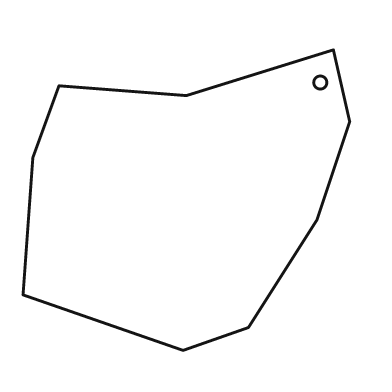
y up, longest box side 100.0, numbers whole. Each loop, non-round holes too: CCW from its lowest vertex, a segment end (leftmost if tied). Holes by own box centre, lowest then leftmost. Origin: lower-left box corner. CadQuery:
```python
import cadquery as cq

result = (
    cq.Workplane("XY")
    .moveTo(49.0, 0.0)
    .lineTo(69.0, 7.0)
    .lineTo(90.0, 40.0)
    .lineTo(100.0, 70.0)
    .lineTo(95.0, 92.0)
    .lineTo(50.0, 78.0)
    .lineTo(11.0, 81.0)
    .lineTo(3.0, 59.0)
    .lineTo(0.0, 17.0)
    .close()
    .moveTo(91.0, 82.0)
    .circle(2.0)
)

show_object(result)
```